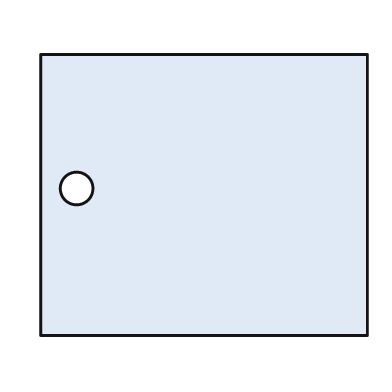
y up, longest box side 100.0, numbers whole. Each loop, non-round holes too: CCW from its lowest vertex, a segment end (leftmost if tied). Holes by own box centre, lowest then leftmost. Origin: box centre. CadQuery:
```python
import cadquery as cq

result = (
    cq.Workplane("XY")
    .moveTo(-50.0, -43.0)
    .lineTo(50.0, -43.0)
    .lineTo(50.0, 43.0)
    .lineTo(-50.0, 43.0)
    .close()
    .moveTo(-39.0, 2.0)
    .circle(5.0)
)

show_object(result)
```